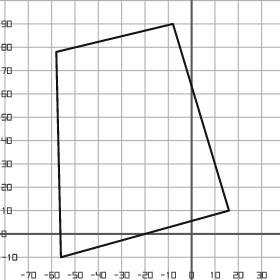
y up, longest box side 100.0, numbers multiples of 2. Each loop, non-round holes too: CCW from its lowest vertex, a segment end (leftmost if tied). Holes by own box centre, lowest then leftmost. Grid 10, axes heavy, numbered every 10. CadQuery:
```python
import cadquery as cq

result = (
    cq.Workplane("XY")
    .moveTo(-56.0, -10.0)
    .lineTo(16.0, 10.0)
    .lineTo(-8.0, 90.0)
    .lineTo(-58.0, 78.0)
    .close()
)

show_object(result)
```